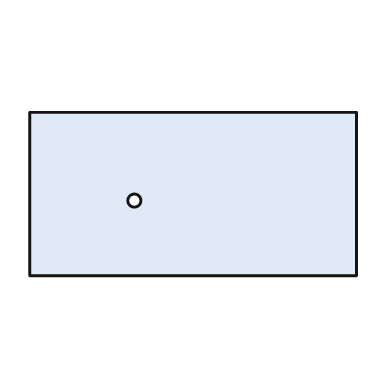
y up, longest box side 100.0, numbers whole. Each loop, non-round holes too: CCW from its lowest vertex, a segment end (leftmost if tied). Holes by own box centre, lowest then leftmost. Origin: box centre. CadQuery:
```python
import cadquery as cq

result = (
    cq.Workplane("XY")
    .moveTo(-50.0, -25.0)
    .lineTo(50.0, -25.0)
    .lineTo(50.0, 25.0)
    .lineTo(-50.0, 25.0)
    .close()
    .moveTo(-18.0, -2.0)
    .circle(2.0)
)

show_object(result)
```